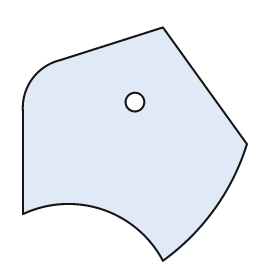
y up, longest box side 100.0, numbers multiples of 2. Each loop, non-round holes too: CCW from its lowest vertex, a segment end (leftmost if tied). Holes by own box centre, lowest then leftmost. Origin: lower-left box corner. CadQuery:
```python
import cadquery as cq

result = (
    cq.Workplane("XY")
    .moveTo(60.0, 0.0)
    .threePointArc((82.0, 22.0), (96.0, 50.0))
    .lineTo(60.0, 100.0)
    .lineTo(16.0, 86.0)
    .threePointArc((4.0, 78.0), (0.0, 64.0))
    .lineTo(0.0, 20.0)
    .threePointArc((34.0, 22.0), (60.0, 0.0))
    .close()
    .moveTo(48.0, 68.0)
    .circle(4.0)
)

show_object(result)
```